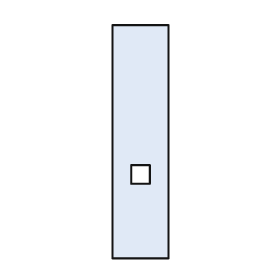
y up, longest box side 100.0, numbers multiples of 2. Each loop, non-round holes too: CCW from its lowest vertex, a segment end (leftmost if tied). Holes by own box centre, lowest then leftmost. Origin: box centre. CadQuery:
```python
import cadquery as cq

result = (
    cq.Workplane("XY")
    .moveTo(-12.0, -50.0)
    .lineTo(12.0, -50.0)
    .lineTo(12.0, 50.0)
    .lineTo(-12.0, 50.0)
    .close()
    .moveTo(-4.0, -18.0)
    .lineTo(4.0, -18.0)
    .lineTo(4.0, -10.0)
    .lineTo(-4.0, -10.0)
    .close()
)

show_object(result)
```